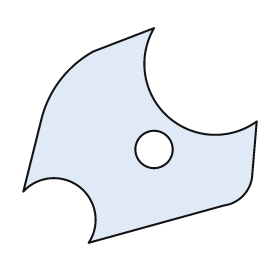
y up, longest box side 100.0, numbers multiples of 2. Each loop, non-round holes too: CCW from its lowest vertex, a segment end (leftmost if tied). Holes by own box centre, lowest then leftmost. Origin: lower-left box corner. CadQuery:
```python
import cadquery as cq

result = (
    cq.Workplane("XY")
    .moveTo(28.0, 0.0)
    .lineTo(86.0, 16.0)
    .threePointArc((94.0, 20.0), (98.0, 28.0))
    .lineTo(100.0, 52.0)
    .threePointArc((62.0, 54.0), (56.0, 92.0))
    .lineTo(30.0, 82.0)
    .threePointArc((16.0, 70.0), (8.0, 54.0))
    .lineTo(0.0, 22.0)
    .threePointArc((24.0, 24.0), (28.0, 0.0))
    .close()
    .moveTo(56.0, 40.0)
    .circle(8.0)
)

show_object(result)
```